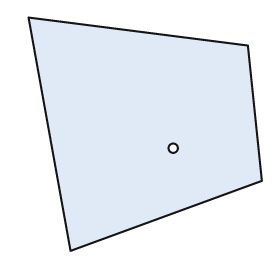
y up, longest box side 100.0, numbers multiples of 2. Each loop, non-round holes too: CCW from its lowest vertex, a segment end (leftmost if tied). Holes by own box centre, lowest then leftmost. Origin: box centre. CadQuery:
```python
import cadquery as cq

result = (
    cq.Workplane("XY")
    .moveTo(-32.0, -50.0)
    .lineTo(50.0, -20.0)
    .lineTo(44.0, 38.0)
    .lineTo(-50.0, 50.0)
    .close()
    .moveTo(12.0, -6.0)
    .circle(2.0)
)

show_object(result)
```